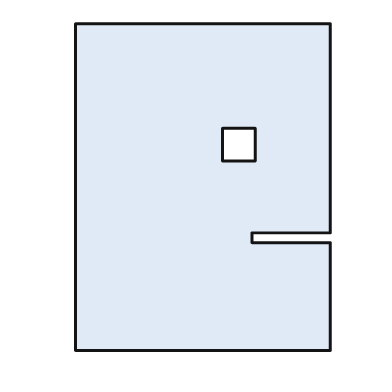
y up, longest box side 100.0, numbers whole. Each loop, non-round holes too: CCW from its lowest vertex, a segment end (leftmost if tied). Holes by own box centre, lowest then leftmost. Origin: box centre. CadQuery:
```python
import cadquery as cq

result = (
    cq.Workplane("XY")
    .moveTo(-39.0, -50.0)
    .lineTo(39.0, -50.0)
    .lineTo(39.0, -17.0)
    .lineTo(15.0, -17.0)
    .lineTo(15.0, -14.0)
    .lineTo(39.0, -14.0)
    .lineTo(39.0, 50.0)
    .lineTo(-39.0, 50.0)
    .close()
    .moveTo(6.0, 8.0)
    .lineTo(16.0, 8.0)
    .lineTo(16.0, 18.0)
    .lineTo(6.0, 18.0)
    .close()
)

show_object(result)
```